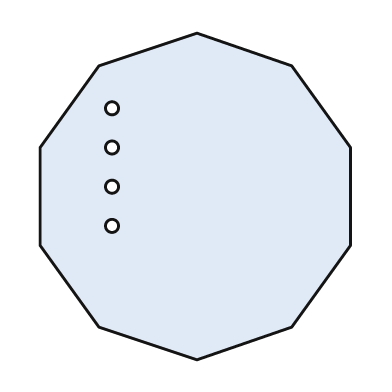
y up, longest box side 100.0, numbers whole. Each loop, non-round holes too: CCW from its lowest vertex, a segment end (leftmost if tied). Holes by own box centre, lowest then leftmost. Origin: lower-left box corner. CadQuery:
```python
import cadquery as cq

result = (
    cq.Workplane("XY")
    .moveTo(48.0, 0.0)
    .lineTo(77.0, 10.0)
    .lineTo(95.0, 35.0)
    .lineTo(95.0, 65.0)
    .lineTo(77.0, 90.0)
    .lineTo(48.0, 100.0)
    .lineTo(18.0, 90.0)
    .lineTo(0.0, 65.0)
    .lineTo(0.0, 35.0)
    .lineTo(18.0, 10.0)
    .close()
    .moveTo(22.0, 41.0)
    .circle(2.0)
    .moveTo(22.0, 53.0)
    .circle(2.0)
    .moveTo(22.0, 65.0)
    .circle(2.0)
    .moveTo(22.0, 77.0)
    .circle(2.0)
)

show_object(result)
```